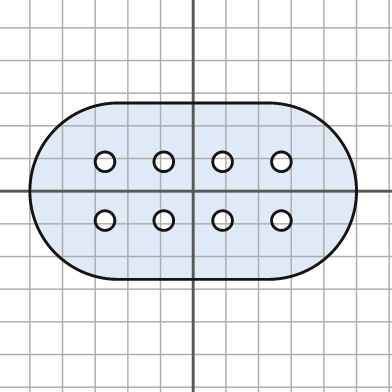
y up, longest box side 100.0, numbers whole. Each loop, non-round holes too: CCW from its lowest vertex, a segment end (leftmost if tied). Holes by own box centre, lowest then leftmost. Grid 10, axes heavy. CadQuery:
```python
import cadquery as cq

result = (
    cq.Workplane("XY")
    .moveTo(-23.0, -27.0)
    .lineTo(23.0, -27.0)
    .threePointArc((50.0, 0.0), (23.0, 27.0))
    .lineTo(-23.0, 27.0)
    .threePointArc((-50.0, 0.0), (-23.0, -27.0))
    .close()
    .moveTo(-27.0, -9.0)
    .circle(3.0)
    .moveTo(-9.0, -9.0)
    .circle(3.0)
    .moveTo(9.0, -9.0)
    .circle(3.0)
    .moveTo(27.0, -9.0)
    .circle(3.0)
    .moveTo(-27.0, 9.0)
    .circle(3.0)
    .moveTo(-9.0, 9.0)
    .circle(3.0)
    .moveTo(9.0, 9.0)
    .circle(3.0)
    .moveTo(27.0, 9.0)
    .circle(3.0)
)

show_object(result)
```